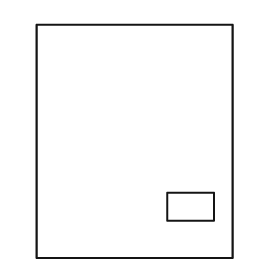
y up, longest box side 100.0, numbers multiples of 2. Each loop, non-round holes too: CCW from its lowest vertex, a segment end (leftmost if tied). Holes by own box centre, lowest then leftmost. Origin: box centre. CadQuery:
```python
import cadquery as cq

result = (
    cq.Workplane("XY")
    .moveTo(-42.0, -50.0)
    .lineTo(42.0, -50.0)
    .lineTo(42.0, 50.0)
    .lineTo(-42.0, 50.0)
    .close()
    .moveTo(14.0, -34.0)
    .lineTo(34.0, -34.0)
    .lineTo(34.0, -22.0)
    .lineTo(14.0, -22.0)
    .close()
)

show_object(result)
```